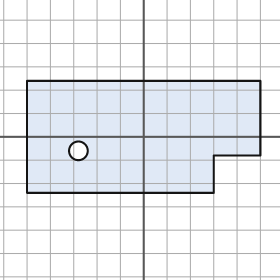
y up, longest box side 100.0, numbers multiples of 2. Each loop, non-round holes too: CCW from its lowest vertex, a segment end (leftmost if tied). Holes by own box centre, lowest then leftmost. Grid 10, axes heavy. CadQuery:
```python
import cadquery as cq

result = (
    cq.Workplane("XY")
    .moveTo(-50.0, -24.0)
    .lineTo(30.0, -24.0)
    .lineTo(30.0, -8.0)
    .lineTo(50.0, -8.0)
    .lineTo(50.0, 24.0)
    .lineTo(-50.0, 24.0)
    .close()
    .moveTo(-28.0, -6.0)
    .circle(4.0)
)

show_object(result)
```